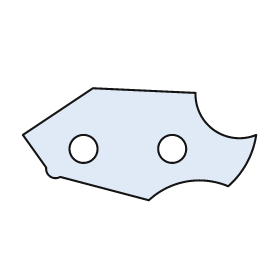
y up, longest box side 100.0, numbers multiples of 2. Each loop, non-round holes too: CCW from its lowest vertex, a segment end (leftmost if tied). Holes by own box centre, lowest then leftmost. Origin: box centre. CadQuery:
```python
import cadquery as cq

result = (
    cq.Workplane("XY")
    .moveTo(4.0, -24.0)
    .threePointArc((20.0, -16.0), (38.0, -18.0))
    .threePointArc((46.0, -8.0), (50.0, 4.0))
    .threePointArc((32.0, 6.0), (24.0, 22.0))
    .lineTo(-20.0, 24.0)
    .lineTo(-50.0, 4.0)
    .lineTo(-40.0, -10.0)
    .threePointArc((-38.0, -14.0), (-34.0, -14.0))
    .close()
    .moveTo(-24.0, -2.0)
    .circle(6.0)
    .moveTo(14.0, -2.0)
    .circle(6.0)
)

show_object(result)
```